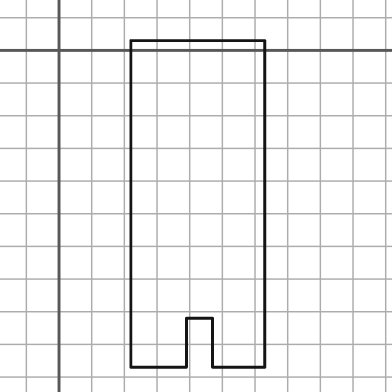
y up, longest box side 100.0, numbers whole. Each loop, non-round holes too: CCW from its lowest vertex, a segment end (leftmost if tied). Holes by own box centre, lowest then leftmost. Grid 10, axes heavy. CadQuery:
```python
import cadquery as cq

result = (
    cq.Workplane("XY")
    .moveTo(22.0, -97.0)
    .lineTo(39.0, -97.0)
    .lineTo(39.0, -82.0)
    .lineTo(47.0, -82.0)
    .lineTo(47.0, -97.0)
    .lineTo(63.0, -97.0)
    .lineTo(63.0, 3.0)
    .lineTo(22.0, 3.0)
    .close()
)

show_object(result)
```